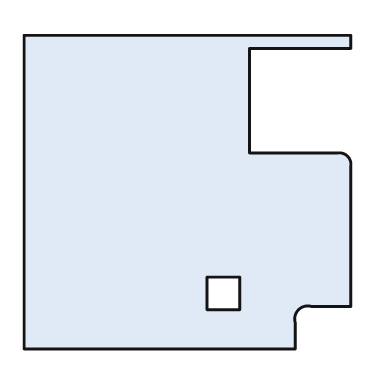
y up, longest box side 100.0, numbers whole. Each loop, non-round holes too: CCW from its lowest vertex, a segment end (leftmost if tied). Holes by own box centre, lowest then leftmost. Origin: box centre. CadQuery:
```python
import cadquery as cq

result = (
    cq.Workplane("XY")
    .moveTo(-50.0, -48.0)
    .lineTo(33.0, -48.0)
    .lineTo(33.0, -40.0)
    .threePointArc((34.0, -36.0), (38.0, -35.0))
    .lineTo(50.0, -35.0)
    .lineTo(50.0, 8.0)
    .threePointArc((49.0, 11.0), (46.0, 12.0))
    .lineTo(19.0, 12.0)
    .lineTo(19.0, 44.0)
    .lineTo(50.0, 44.0)
    .lineTo(50.0, 48.0)
    .lineTo(-50.0, 48.0)
    .close()
    .moveTo(6.0, -36.0)
    .lineTo(16.0, -36.0)
    .lineTo(16.0, -26.0)
    .lineTo(6.0, -26.0)
    .close()
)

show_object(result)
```